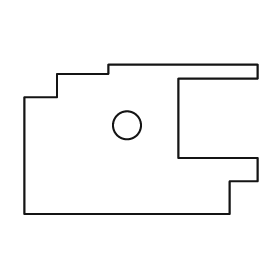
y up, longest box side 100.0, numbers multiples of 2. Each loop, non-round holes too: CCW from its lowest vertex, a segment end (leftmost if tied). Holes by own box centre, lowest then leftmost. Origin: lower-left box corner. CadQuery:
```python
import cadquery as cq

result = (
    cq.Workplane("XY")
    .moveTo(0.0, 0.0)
    .lineTo(88.0, 0.0)
    .lineTo(88.0, 14.0)
    .lineTo(100.0, 14.0)
    .lineTo(100.0, 24.0)
    .lineTo(66.0, 24.0)
    .lineTo(66.0, 58.0)
    .lineTo(100.0, 58.0)
    .lineTo(100.0, 64.0)
    .lineTo(36.0, 64.0)
    .lineTo(36.0, 60.0)
    .lineTo(14.0, 60.0)
    .lineTo(14.0, 50.0)
    .lineTo(0.0, 50.0)
    .close()
    .moveTo(44.0, 38.0)
    .circle(6.0)
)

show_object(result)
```